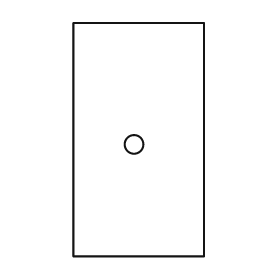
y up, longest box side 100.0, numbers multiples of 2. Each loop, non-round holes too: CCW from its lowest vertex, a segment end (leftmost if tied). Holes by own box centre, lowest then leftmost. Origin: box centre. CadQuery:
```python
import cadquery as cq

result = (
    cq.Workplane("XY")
    .moveTo(-28.0, -50.0)
    .lineTo(28.0, -50.0)
    .lineTo(28.0, 50.0)
    .lineTo(-28.0, 50.0)
    .close()
    .moveTo(-2.0, -2.0)
    .circle(4.0)
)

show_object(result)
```